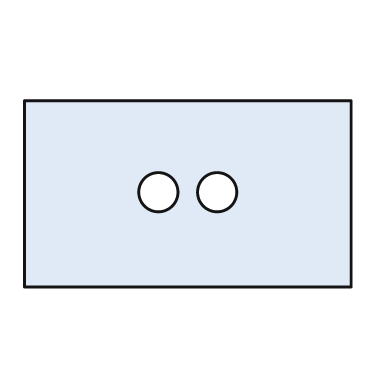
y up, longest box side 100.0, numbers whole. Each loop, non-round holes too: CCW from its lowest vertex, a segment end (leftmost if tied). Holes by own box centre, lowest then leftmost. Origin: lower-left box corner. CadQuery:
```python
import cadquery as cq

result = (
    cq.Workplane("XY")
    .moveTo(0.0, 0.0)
    .lineTo(100.0, 0.0)
    .lineTo(100.0, 57.0)
    .lineTo(0.0, 57.0)
    .close()
    .moveTo(41.0, 29.0)
    .circle(6.0)
    .moveTo(59.0, 29.0)
    .circle(6.0)
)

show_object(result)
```